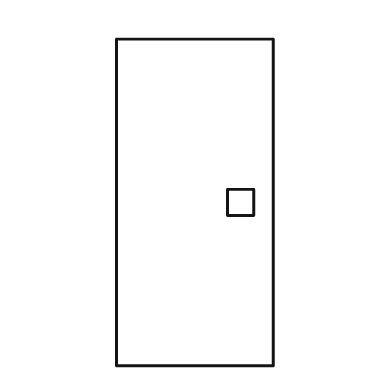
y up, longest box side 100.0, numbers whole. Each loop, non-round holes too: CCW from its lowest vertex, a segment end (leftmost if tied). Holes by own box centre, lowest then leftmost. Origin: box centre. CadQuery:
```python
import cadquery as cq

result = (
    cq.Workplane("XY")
    .moveTo(-24.0, -50.0)
    .lineTo(24.0, -50.0)
    .lineTo(24.0, 50.0)
    .lineTo(-24.0, 50.0)
    .close()
    .moveTo(10.0, -4.0)
    .lineTo(18.0, -4.0)
    .lineTo(18.0, 4.0)
    .lineTo(10.0, 4.0)
    .close()
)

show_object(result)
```